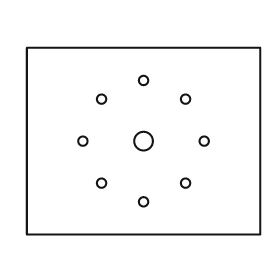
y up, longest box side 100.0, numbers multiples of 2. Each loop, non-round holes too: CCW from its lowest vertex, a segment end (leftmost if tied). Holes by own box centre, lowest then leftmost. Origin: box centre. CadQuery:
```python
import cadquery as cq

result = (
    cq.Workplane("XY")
    .moveTo(-50.0, -40.0)
    .lineTo(50.0, -40.0)
    .lineTo(50.0, 40.0)
    .lineTo(-50.0, 40.0)
    .close()
    .moveTo(0.0, -26.0)
    .circle(2.0)
    .moveTo(-18.0, -18.0)
    .circle(2.0)
    .moveTo(18.0, -18.0)
    .circle(2.0)
    .moveTo(-26.0, 0.0)
    .circle(2.0)
    .moveTo(0.0, 0.0)
    .circle(4.0)
    .moveTo(26.0, 0.0)
    .circle(2.0)
    .moveTo(-18.0, 18.0)
    .circle(2.0)
    .moveTo(18.0, 18.0)
    .circle(2.0)
    .moveTo(0.0, 26.0)
    .circle(2.0)
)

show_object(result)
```